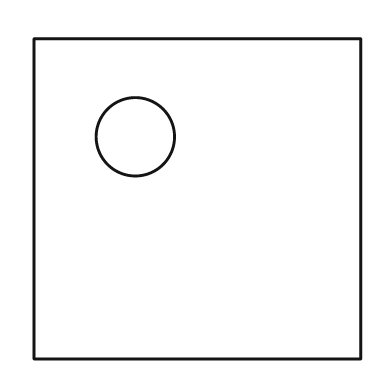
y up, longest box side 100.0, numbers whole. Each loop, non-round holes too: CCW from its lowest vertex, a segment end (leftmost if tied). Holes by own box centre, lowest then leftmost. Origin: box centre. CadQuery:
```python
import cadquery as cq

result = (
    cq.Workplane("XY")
    .moveTo(-50.0, -49.0)
    .lineTo(50.0, -49.0)
    .lineTo(50.0, 49.0)
    .lineTo(-50.0, 49.0)
    .close()
    .moveTo(-19.0, 19.0)
    .circle(12.0)
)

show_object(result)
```